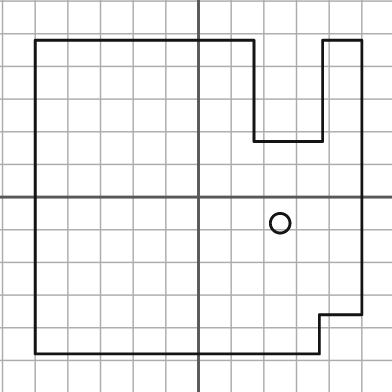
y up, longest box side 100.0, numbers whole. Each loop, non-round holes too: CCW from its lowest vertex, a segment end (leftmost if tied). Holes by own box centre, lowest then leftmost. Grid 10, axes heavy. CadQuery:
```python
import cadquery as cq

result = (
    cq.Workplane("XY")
    .moveTo(-50.0, -48.0)
    .lineTo(37.0, -48.0)
    .lineTo(37.0, -36.0)
    .lineTo(50.0, -36.0)
    .lineTo(50.0, 48.0)
    .lineTo(38.0, 48.0)
    .lineTo(38.0, 17.0)
    .lineTo(17.0, 17.0)
    .lineTo(17.0, 48.0)
    .lineTo(-50.0, 48.0)
    .close()
    .moveTo(25.0, -8.0)
    .circle(3.0)
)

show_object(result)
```